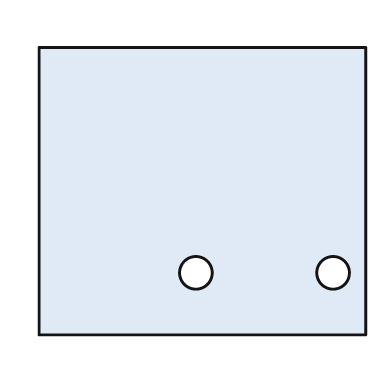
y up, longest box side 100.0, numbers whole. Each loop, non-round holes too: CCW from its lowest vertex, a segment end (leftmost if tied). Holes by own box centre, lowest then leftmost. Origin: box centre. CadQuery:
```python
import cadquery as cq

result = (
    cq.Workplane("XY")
    .moveTo(-50.0, -44.0)
    .lineTo(50.0, -44.0)
    .lineTo(50.0, 44.0)
    .lineTo(-50.0, 44.0)
    .close()
    .moveTo(-2.0, -25.0)
    .circle(5.0)
    .moveTo(40.0, -25.0)
    .circle(5.0)
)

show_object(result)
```